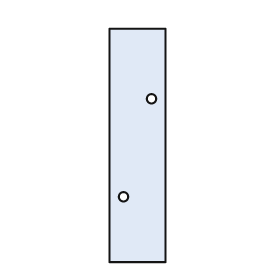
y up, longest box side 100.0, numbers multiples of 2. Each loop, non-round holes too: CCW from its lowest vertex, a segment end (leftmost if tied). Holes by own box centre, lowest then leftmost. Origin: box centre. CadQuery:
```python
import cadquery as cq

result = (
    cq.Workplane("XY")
    .moveTo(-12.0, -50.0)
    .lineTo(12.0, -50.0)
    .lineTo(12.0, 50.0)
    .lineTo(-12.0, 50.0)
    .close()
    .moveTo(-6.0, -22.0)
    .circle(2.0)
    .moveTo(6.0, 20.0)
    .circle(2.0)
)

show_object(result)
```